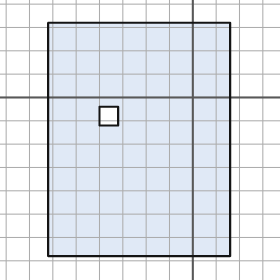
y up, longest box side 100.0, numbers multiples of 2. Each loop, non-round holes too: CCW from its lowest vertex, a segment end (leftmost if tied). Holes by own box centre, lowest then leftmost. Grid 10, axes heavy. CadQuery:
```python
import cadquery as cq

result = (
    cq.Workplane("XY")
    .moveTo(-62.0, -68.0)
    .lineTo(16.0, -68.0)
    .lineTo(16.0, 32.0)
    .lineTo(-62.0, 32.0)
    .close()
    .moveTo(-40.0, -12.0)
    .lineTo(-32.0, -12.0)
    .lineTo(-32.0, -4.0)
    .lineTo(-40.0, -4.0)
    .close()
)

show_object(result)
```